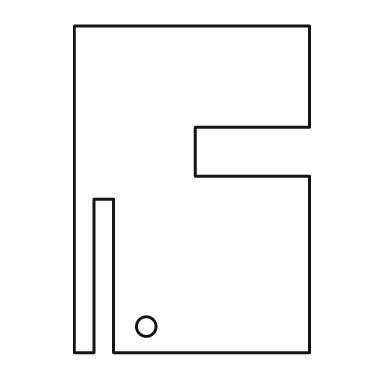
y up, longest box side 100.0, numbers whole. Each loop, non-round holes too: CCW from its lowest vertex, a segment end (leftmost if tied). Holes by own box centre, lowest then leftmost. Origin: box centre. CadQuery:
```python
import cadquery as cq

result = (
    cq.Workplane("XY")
    .moveTo(-36.0, -50.0)
    .lineTo(-30.0, -50.0)
    .lineTo(-30.0, -3.0)
    .lineTo(-24.0, -3.0)
    .lineTo(-24.0, -50.0)
    .lineTo(36.0, -50.0)
    .lineTo(36.0, 4.0)
    .lineTo(1.0, 4.0)
    .lineTo(1.0, 19.0)
    .lineTo(36.0, 19.0)
    .lineTo(36.0, 50.0)
    .lineTo(-36.0, 50.0)
    .close()
    .moveTo(-14.0, -42.0)
    .circle(3.0)
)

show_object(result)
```